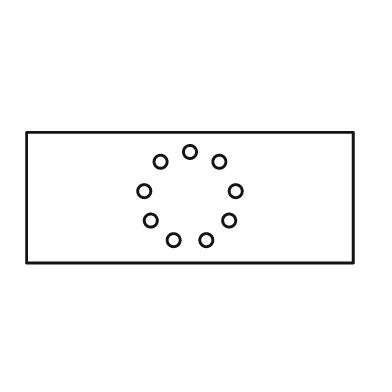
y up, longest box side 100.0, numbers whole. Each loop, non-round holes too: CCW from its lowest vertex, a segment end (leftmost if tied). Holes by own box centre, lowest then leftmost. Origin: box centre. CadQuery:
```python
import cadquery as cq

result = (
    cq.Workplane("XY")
    .moveTo(-50.0, -20.0)
    .lineTo(50.0, -20.0)
    .lineTo(50.0, 20.0)
    .lineTo(-50.0, 20.0)
    .close()
    .moveTo(-5.0, -13.0)
    .circle(2.0)
    .moveTo(5.0, -13.0)
    .circle(2.0)
    .moveTo(-12.0, -7.0)
    .circle(2.0)
    .moveTo(12.0, -7.0)
    .circle(2.0)
    .moveTo(-14.0, 2.0)
    .circle(2.0)
    .moveTo(14.0, 2.0)
    .circle(2.0)
    .moveTo(-9.0, 11.0)
    .circle(2.0)
    .moveTo(9.0, 11.0)
    .circle(2.0)
    .moveTo(0.0, 14.0)
    .circle(2.0)
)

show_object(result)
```